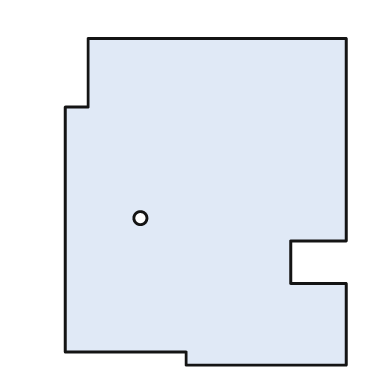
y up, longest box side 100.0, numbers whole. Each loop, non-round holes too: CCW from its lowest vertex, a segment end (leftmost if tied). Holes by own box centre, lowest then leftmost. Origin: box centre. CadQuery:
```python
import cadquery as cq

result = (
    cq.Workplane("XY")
    .moveTo(-6.0, -50.0)
    .lineTo(43.0, -50.0)
    .lineTo(43.0, -25.0)
    .lineTo(26.0, -25.0)
    .lineTo(26.0, -12.0)
    .lineTo(43.0, -12.0)
    .lineTo(43.0, 50.0)
    .lineTo(-36.0, 50.0)
    .lineTo(-36.0, 29.0)
    .lineTo(-43.0, 29.0)
    .lineTo(-43.0, -46.0)
    .lineTo(-6.0, -46.0)
    .close()
    .moveTo(-20.0, -5.0)
    .circle(2.0)
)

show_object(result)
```